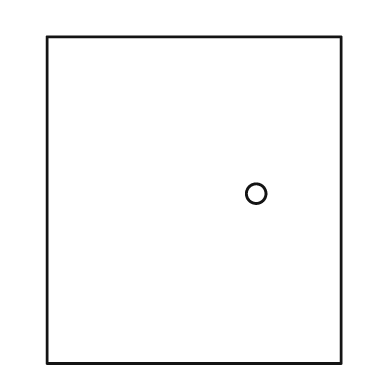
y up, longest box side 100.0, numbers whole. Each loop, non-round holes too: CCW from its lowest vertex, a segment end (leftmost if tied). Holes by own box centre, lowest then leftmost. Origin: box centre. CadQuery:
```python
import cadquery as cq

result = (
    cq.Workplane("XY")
    .moveTo(-45.0, -50.0)
    .lineTo(45.0, -50.0)
    .lineTo(45.0, 50.0)
    .lineTo(-45.0, 50.0)
    .close()
    .moveTo(19.0, 2.0)
    .circle(3.0)
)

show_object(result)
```